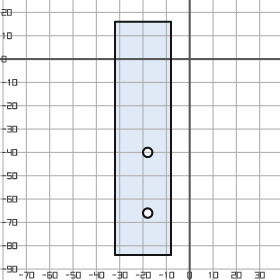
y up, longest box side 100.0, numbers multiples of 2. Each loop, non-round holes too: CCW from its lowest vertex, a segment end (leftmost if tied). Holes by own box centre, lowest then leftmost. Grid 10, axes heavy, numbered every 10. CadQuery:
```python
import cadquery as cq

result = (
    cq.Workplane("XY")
    .moveTo(-32.0, -84.0)
    .lineTo(-8.0, -84.0)
    .lineTo(-8.0, 16.0)
    .lineTo(-32.0, 16.0)
    .close()
    .moveTo(-18.0, -66.0)
    .circle(2.0)
    .moveTo(-18.0, -40.0)
    .circle(2.0)
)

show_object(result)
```